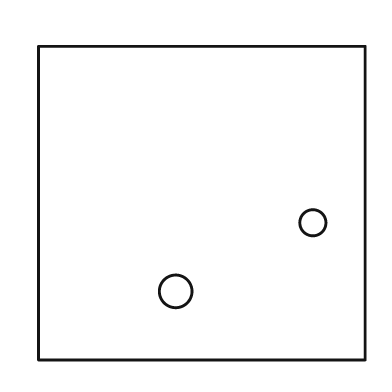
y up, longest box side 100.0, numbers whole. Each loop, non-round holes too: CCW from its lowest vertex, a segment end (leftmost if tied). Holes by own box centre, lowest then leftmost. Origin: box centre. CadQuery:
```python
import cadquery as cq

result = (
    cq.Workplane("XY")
    .moveTo(-50.0, -48.0)
    .lineTo(50.0, -48.0)
    .lineTo(50.0, 48.0)
    .lineTo(-50.0, 48.0)
    .close()
    .moveTo(-8.0, -27.0)
    .circle(5.0)
    .moveTo(34.0, -6.0)
    .circle(4.0)
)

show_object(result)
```